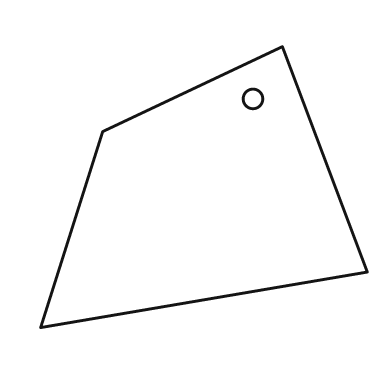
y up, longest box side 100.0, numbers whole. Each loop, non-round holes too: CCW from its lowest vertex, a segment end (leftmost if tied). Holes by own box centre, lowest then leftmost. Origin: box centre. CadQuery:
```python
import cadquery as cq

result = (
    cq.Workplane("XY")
    .moveTo(-50.0, -43.0)
    .lineTo(50.0, -26.0)
    .lineTo(24.0, 43.0)
    .lineTo(-31.0, 17.0)
    .close()
    .moveTo(15.0, 27.0)
    .circle(3.0)
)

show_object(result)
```